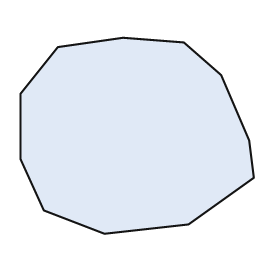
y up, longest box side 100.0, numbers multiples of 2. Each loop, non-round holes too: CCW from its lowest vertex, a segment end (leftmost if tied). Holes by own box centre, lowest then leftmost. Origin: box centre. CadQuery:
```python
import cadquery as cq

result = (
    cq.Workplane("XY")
    .moveTo(-14.0, -42.0)
    .lineTo(22.0, -38.0)
    .lineTo(50.0, -18.0)
    .lineTo(48.0, -2.0)
    .lineTo(36.0, 26.0)
    .lineTo(20.0, 40.0)
    .lineTo(-6.0, 42.0)
    .lineTo(-34.0, 38.0)
    .lineTo(-50.0, 18.0)
    .lineTo(-50.0, -10.0)
    .lineTo(-40.0, -32.0)
    .close()
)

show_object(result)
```